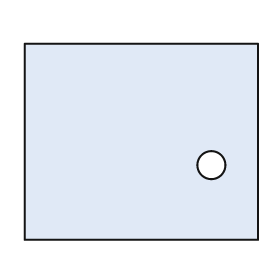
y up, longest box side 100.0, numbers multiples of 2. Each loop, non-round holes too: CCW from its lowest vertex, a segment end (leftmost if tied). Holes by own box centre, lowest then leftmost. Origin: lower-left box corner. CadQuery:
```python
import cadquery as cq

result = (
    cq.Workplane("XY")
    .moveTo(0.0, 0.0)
    .lineTo(100.0, 0.0)
    .lineTo(100.0, 84.0)
    .lineTo(0.0, 84.0)
    .close()
    .moveTo(80.0, 32.0)
    .circle(6.0)
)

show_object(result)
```